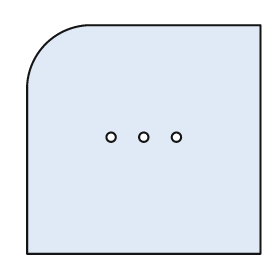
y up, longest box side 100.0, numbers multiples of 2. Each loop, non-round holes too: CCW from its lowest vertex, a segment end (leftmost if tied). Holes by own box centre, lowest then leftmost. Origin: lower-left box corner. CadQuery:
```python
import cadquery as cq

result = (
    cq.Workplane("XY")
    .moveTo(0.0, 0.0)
    .lineTo(100.0, 0.0)
    .lineTo(100.0, 98.0)
    .lineTo(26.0, 98.0)
    .threePointArc((8.0, 90.0), (0.0, 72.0))
    .close()
    .moveTo(36.0, 50.0)
    .circle(2.0)
    .moveTo(50.0, 50.0)
    .circle(2.0)
    .moveTo(64.0, 50.0)
    .circle(2.0)
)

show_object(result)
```